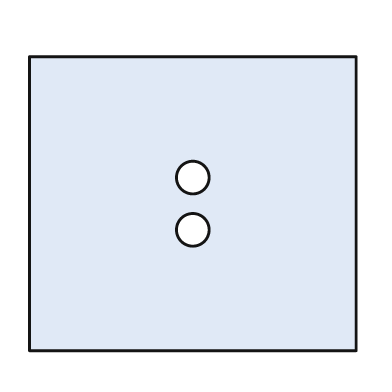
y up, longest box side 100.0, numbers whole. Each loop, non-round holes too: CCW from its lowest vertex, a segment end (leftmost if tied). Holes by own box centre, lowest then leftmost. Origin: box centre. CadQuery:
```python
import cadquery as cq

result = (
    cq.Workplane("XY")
    .moveTo(-50.0, -45.0)
    .lineTo(50.0, -45.0)
    .lineTo(50.0, 45.0)
    .lineTo(-50.0, 45.0)
    .close()
    .moveTo(0.0, -8.0)
    .circle(5.0)
    .moveTo(0.0, 8.0)
    .circle(5.0)
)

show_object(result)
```